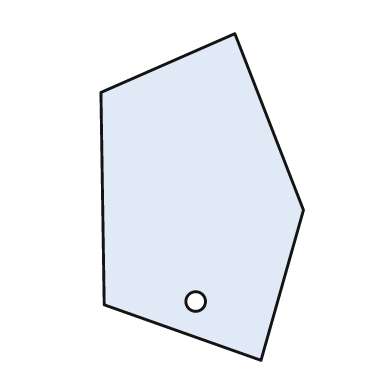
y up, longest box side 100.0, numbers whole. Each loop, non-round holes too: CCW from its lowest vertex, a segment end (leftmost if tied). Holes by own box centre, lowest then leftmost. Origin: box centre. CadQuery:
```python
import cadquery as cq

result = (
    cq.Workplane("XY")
    .moveTo(18.0, -50.0)
    .lineTo(31.0, -4.0)
    .lineTo(10.0, 50.0)
    .lineTo(-31.0, 32.0)
    .lineTo(-30.0, -33.0)
    .close()
    .moveTo(-2.0, -32.0)
    .circle(3.0)
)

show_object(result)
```